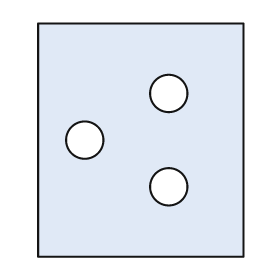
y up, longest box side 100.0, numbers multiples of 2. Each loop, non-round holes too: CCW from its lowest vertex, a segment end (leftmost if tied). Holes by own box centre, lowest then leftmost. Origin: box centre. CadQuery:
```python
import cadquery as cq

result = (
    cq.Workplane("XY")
    .moveTo(-44.0, -50.0)
    .lineTo(44.0, -50.0)
    .lineTo(44.0, 50.0)
    .lineTo(-44.0, 50.0)
    .close()
    .moveTo(12.0, -20.0)
    .circle(8.0)
    .moveTo(-24.0, 0.0)
    .circle(8.0)
    .moveTo(12.0, 20.0)
    .circle(8.0)
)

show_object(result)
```